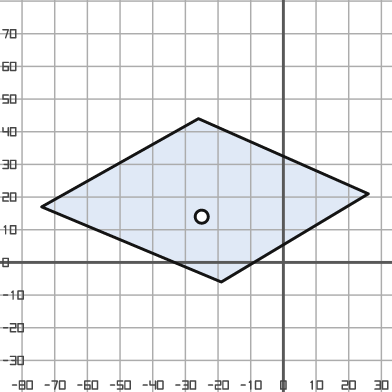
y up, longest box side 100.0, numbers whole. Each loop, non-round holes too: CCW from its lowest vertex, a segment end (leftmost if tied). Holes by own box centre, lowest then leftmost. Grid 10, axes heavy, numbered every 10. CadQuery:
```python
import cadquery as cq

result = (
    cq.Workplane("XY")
    .moveTo(-19.0, -6.0)
    .lineTo(26.0, 21.0)
    .lineTo(-26.0, 44.0)
    .lineTo(-74.0, 17.0)
    .close()
    .moveTo(-25.0, 14.0)
    .circle(2.0)
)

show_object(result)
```